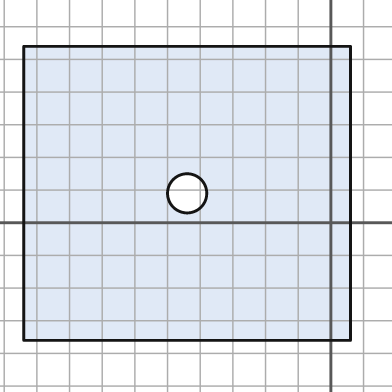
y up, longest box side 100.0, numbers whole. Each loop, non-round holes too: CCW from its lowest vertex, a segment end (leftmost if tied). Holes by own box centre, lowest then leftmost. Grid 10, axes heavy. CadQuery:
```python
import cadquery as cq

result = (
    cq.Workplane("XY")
    .moveTo(-94.0, -36.0)
    .lineTo(6.0, -36.0)
    .lineTo(6.0, 54.0)
    .lineTo(-94.0, 54.0)
    .close()
    .moveTo(-44.0, 9.0)
    .circle(6.0)
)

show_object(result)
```